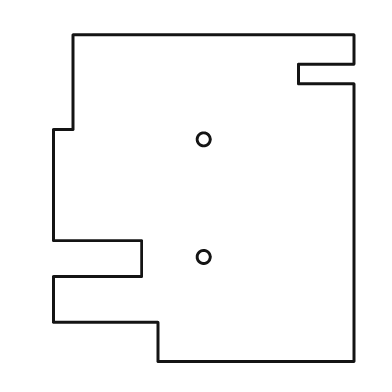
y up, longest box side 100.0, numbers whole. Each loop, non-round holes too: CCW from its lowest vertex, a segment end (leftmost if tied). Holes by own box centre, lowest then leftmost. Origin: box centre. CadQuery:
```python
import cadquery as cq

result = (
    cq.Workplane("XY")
    .moveTo(-14.0, -50.0)
    .lineTo(46.0, -50.0)
    .lineTo(46.0, 35.0)
    .lineTo(29.0, 35.0)
    .lineTo(29.0, 41.0)
    .lineTo(46.0, 41.0)
    .lineTo(46.0, 50.0)
    .lineTo(-40.0, 50.0)
    .lineTo(-40.0, 21.0)
    .lineTo(-46.0, 21.0)
    .lineTo(-46.0, -13.0)
    .lineTo(-19.0, -13.0)
    .lineTo(-19.0, -24.0)
    .lineTo(-46.0, -24.0)
    .lineTo(-46.0, -38.0)
    .lineTo(-14.0, -38.0)
    .close()
    .moveTo(0.0, -18.0)
    .circle(2.0)
    .moveTo(0.0, 18.0)
    .circle(2.0)
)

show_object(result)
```